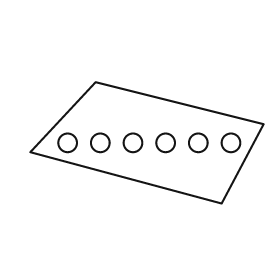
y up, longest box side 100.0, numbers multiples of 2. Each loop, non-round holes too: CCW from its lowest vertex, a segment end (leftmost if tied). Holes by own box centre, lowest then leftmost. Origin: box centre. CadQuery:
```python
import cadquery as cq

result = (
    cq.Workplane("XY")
    .moveTo(32.0, -26.0)
    .lineTo(50.0, 8.0)
    .lineTo(-22.0, 26.0)
    .lineTo(-50.0, -4.0)
    .close()
    .moveTo(-34.0, 0.0)
    .circle(4.0)
    .moveTo(-20.0, 0.0)
    .circle(4.0)
    .moveTo(-6.0, 0.0)
    .circle(4.0)
    .moveTo(8.0, 0.0)
    .circle(4.0)
    .moveTo(22.0, 0.0)
    .circle(4.0)
    .moveTo(36.0, 0.0)
    .circle(4.0)
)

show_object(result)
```